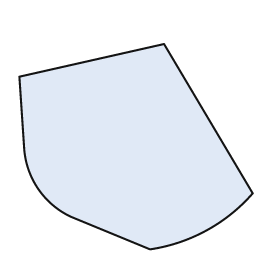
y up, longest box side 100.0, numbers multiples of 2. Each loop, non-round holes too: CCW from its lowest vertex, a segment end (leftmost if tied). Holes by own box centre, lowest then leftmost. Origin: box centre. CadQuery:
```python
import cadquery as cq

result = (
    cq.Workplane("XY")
    .moveTo(6.0, -44.0)
    .threePointArc((30.0, -36.0), (50.0, -20.0))
    .lineTo(12.0, 44.0)
    .lineTo(-50.0, 30.0)
    .lineTo(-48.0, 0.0)
    .threePointArc((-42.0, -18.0), (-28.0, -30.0))
    .close()
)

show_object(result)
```